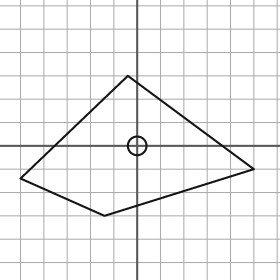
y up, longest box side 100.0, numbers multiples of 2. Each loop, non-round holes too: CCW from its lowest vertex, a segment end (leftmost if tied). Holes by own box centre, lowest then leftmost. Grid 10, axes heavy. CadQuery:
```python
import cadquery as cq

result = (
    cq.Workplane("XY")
    .moveTo(-14.0, -30.0)
    .lineTo(50.0, -10.0)
    .lineTo(-4.0, 30.0)
    .lineTo(-50.0, -14.0)
    .close()
    .moveTo(0.0, 0.0)
    .circle(4.0)
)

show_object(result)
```